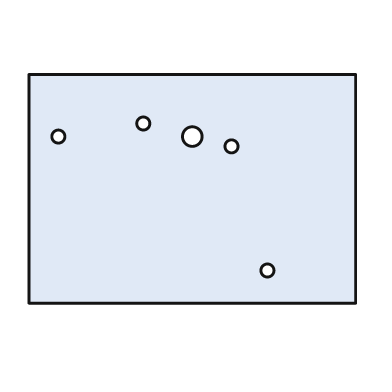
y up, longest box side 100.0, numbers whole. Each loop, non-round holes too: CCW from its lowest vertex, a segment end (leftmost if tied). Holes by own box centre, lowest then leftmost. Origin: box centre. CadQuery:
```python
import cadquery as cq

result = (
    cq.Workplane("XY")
    .moveTo(-50.0, -35.0)
    .lineTo(50.0, -35.0)
    .lineTo(50.0, 35.0)
    .lineTo(-50.0, 35.0)
    .close()
    .moveTo(23.0, -25.0)
    .circle(2.0)
    .moveTo(12.0, 13.0)
    .circle(2.0)
    .moveTo(-41.0, 16.0)
    .circle(2.0)
    .moveTo(0.0, 16.0)
    .circle(3.0)
    .moveTo(-15.0, 20.0)
    .circle(2.0)
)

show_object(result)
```